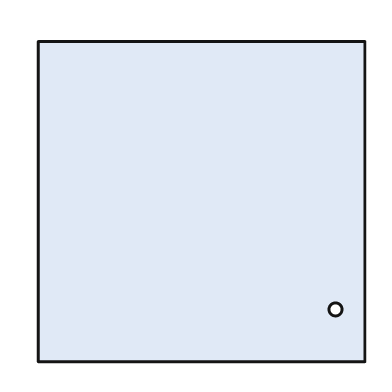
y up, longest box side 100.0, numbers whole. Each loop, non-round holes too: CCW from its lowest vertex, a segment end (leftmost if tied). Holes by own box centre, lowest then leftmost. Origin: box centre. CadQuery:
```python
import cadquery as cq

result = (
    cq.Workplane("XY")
    .moveTo(-50.0, -49.0)
    .lineTo(50.0, -49.0)
    .lineTo(50.0, 49.0)
    .lineTo(-50.0, 49.0)
    .close()
    .moveTo(41.0, -33.0)
    .circle(2.0)
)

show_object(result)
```